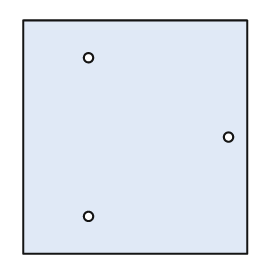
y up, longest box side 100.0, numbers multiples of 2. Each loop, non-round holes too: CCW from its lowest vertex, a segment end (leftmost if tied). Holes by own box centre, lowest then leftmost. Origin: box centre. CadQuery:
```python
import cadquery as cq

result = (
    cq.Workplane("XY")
    .moveTo(-48.0, -50.0)
    .lineTo(48.0, -50.0)
    .lineTo(48.0, 50.0)
    .lineTo(-48.0, 50.0)
    .close()
    .moveTo(-20.0, -34.0)
    .circle(2.0)
    .moveTo(40.0, 0.0)
    .circle(2.0)
    .moveTo(-20.0, 34.0)
    .circle(2.0)
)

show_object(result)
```